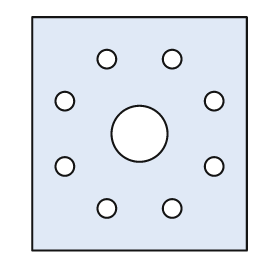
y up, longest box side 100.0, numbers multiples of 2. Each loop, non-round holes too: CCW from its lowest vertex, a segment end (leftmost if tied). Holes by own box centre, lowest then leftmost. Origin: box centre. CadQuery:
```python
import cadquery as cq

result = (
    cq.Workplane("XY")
    .moveTo(-46.0, -50.0)
    .lineTo(46.0, -50.0)
    .lineTo(46.0, 50.0)
    .lineTo(-46.0, 50.0)
    .close()
    .moveTo(-14.0, -32.0)
    .circle(4.0)
    .moveTo(14.0, -32.0)
    .circle(4.0)
    .moveTo(-32.0, -14.0)
    .circle(4.0)
    .moveTo(32.0, -14.0)
    .circle(4.0)
    .moveTo(0.0, 0.0)
    .circle(12.0)
    .moveTo(-32.0, 14.0)
    .circle(4.0)
    .moveTo(32.0, 14.0)
    .circle(4.0)
    .moveTo(-14.0, 32.0)
    .circle(4.0)
    .moveTo(14.0, 32.0)
    .circle(4.0)
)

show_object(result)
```